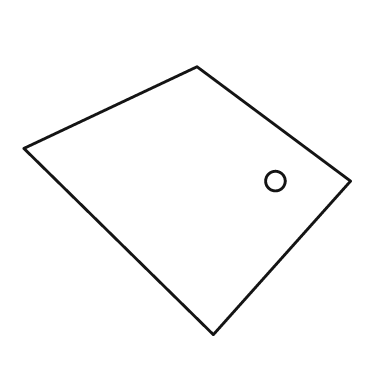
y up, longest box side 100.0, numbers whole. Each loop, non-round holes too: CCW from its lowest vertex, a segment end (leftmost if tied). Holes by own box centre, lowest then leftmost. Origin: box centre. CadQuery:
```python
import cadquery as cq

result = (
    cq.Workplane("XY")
    .moveTo(8.0, -41.0)
    .lineTo(50.0, 6.0)
    .lineTo(3.0, 41.0)
    .lineTo(-50.0, 16.0)
    .close()
    .moveTo(27.0, 6.0)
    .circle(3.0)
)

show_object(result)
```